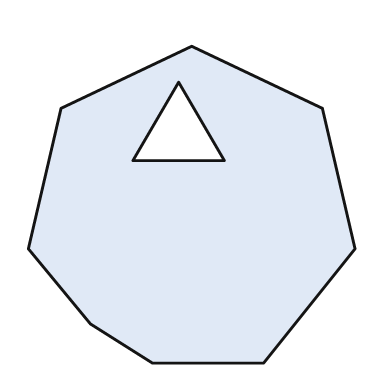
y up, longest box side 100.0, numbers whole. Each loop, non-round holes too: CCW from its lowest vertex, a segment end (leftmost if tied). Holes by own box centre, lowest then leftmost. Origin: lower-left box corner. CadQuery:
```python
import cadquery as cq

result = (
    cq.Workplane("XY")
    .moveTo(38.0, 0.0)
    .lineTo(72.0, 0.0)
    .lineTo(100.0, 35.0)
    .lineTo(90.0, 78.0)
    .lineTo(50.0, 97.0)
    .lineTo(10.0, 78.0)
    .lineTo(0.0, 35.0)
    .lineTo(19.0, 12.0)
    .close()
    .moveTo(32.0, 62.0)
    .lineTo(60.0, 62.0)
    .lineTo(46.0, 86.0)
    .close()
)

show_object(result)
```